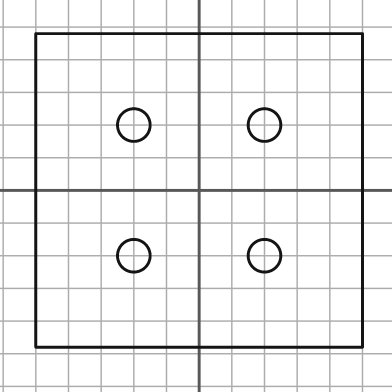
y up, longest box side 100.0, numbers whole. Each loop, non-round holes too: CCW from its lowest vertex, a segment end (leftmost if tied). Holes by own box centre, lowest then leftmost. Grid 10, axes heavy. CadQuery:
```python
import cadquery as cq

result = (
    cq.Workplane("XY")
    .moveTo(-50.0, -48.0)
    .lineTo(50.0, -48.0)
    .lineTo(50.0, 48.0)
    .lineTo(-50.0, 48.0)
    .close()
    .moveTo(-20.0, -20.0)
    .circle(5.0)
    .moveTo(20.0, -20.0)
    .circle(5.0)
    .moveTo(-20.0, 20.0)
    .circle(5.0)
    .moveTo(20.0, 20.0)
    .circle(5.0)
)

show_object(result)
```